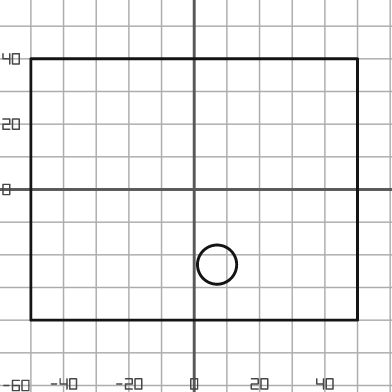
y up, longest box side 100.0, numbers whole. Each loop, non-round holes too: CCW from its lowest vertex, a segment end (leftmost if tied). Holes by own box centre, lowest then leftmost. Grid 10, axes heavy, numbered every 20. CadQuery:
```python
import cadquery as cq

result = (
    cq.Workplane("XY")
    .moveTo(-50.0, -40.0)
    .lineTo(50.0, -40.0)
    .lineTo(50.0, 40.0)
    .lineTo(-50.0, 40.0)
    .close()
    .moveTo(7.0, -23.0)
    .circle(6.0)
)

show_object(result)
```